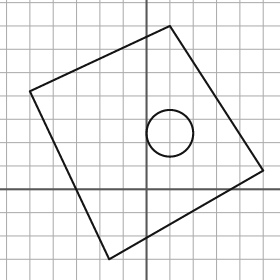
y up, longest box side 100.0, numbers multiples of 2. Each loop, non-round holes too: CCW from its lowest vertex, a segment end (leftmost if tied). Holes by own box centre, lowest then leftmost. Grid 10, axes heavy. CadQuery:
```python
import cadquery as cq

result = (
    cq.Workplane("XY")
    .moveTo(-16.0, -30.0)
    .lineTo(50.0, 8.0)
    .lineTo(10.0, 70.0)
    .lineTo(-50.0, 42.0)
    .close()
    .moveTo(10.0, 24.0)
    .circle(10.0)
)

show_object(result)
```